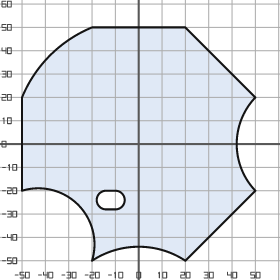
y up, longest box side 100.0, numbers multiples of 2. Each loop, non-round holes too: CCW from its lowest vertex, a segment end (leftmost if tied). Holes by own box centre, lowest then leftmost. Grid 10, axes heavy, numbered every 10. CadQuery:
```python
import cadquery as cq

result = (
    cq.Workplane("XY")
    .moveTo(-20.0, -50.0)
    .threePointArc((0.0, -44.0), (20.0, -50.0))
    .lineTo(50.0, -20.0)
    .threePointArc((42.0, 0.0), (50.0, 20.0))
    .lineTo(20.0, 50.0)
    .lineTo(-20.0, 50.0)
    .threePointArc((-38.0, 38.0), (-50.0, 20.0))
    .lineTo(-50.0, -20.0)
    .threePointArc((-26.0, -26.0), (-20.0, -50.0))
    .close()
    .moveTo(-14.0, -28.0)
    .lineTo(-10.0, -28.0)
    .threePointArc((-6.0, -24.0), (-10.0, -20.0))
    .lineTo(-14.0, -20.0)
    .threePointArc((-18.0, -24.0), (-14.0, -28.0))
    .close()
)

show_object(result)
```